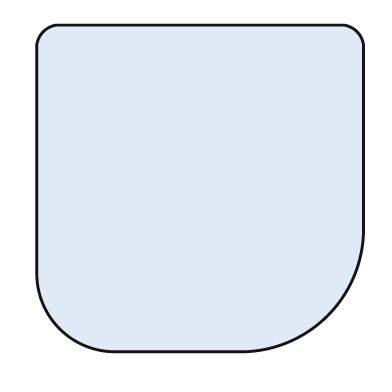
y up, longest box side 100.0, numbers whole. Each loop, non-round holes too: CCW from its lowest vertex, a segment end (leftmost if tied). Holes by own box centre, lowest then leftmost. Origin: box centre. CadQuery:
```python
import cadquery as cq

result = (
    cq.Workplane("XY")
    .moveTo(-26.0, -50.0)
    .lineTo(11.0, -50.0)
    .threePointArc((39.0, -39.0), (50.0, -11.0))
    .lineTo(50.0, 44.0)
    .threePointArc((48.0, 48.0), (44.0, 50.0))
    .lineTo(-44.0, 50.0)
    .threePointArc((-48.0, 48.0), (-50.0, 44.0))
    .lineTo(-50.0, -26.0)
    .threePointArc((-43.0, -43.0), (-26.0, -50.0))
    .close()
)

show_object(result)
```